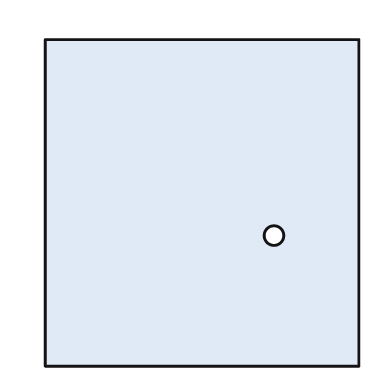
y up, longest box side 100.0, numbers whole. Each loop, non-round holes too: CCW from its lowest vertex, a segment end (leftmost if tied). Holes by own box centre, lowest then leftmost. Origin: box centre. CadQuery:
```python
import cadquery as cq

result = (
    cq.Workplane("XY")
    .moveTo(-48.0, -50.0)
    .lineTo(48.0, -50.0)
    .lineTo(48.0, 50.0)
    .lineTo(-48.0, 50.0)
    .close()
    .moveTo(22.0, -10.0)
    .circle(3.0)
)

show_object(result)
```